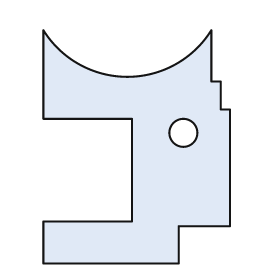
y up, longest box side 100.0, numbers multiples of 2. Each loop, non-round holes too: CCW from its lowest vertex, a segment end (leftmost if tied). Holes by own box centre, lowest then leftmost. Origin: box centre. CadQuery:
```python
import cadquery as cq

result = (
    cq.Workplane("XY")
    .moveTo(-40.0, -50.0)
    .lineTo(18.0, -50.0)
    .lineTo(18.0, -34.0)
    .lineTo(40.0, -34.0)
    .lineTo(40.0, 16.0)
    .lineTo(36.0, 16.0)
    .lineTo(36.0, 28.0)
    .lineTo(32.0, 28.0)
    .lineTo(32.0, 50.0)
    .threePointArc((-4.0, 30.0), (-40.0, 50.0))
    .lineTo(-40.0, 12.0)
    .lineTo(-2.0, 12.0)
    .lineTo(-2.0, -32.0)
    .lineTo(-40.0, -32.0)
    .close()
    .moveTo(20.0, 6.0)
    .circle(6.0)
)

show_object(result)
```